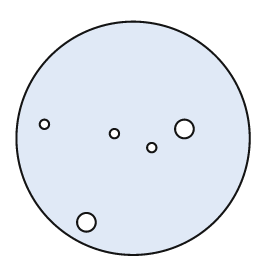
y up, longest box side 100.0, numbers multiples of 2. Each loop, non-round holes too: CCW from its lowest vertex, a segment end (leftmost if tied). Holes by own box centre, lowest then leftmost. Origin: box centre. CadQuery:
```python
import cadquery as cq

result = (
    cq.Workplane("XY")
    .moveTo(0.0, 0.0)
    .circle(50.0)
    .moveTo(-20.0, -36.0)
    .circle(4.0)
    .moveTo(8.0, -4.0)
    .circle(2.0)
    .moveTo(-8.0, 2.0)
    .circle(2.0)
    .moveTo(22.0, 4.0)
    .circle(4.0)
    .moveTo(-38.0, 6.0)
    .circle(2.0)
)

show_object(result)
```